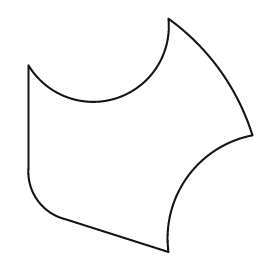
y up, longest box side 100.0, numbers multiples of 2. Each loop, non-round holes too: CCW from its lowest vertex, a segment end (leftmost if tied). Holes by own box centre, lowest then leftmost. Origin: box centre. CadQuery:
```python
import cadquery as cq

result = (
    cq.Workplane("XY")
    .moveTo(12.0, -50.0)
    .threePointArc((20.0, -18.0), (48.0, 0.0))
    .threePointArc((34.0, 28.0), (12.0, 50.0))
    .threePointArc((-10.0, 16.0), (-48.0, 30.0))
    .lineTo(-48.0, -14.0)
    .threePointArc((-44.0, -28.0), (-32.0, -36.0))
    .close()
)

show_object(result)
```